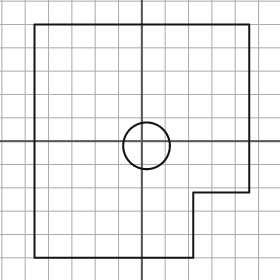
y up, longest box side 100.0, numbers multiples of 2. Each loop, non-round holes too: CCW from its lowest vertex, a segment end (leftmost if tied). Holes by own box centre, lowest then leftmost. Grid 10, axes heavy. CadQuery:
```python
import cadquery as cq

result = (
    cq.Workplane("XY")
    .moveTo(-46.0, -50.0)
    .lineTo(22.0, -50.0)
    .lineTo(22.0, -22.0)
    .lineTo(46.0, -22.0)
    .lineTo(46.0, 50.0)
    .lineTo(-46.0, 50.0)
    .close()
    .moveTo(2.0, -2.0)
    .circle(10.0)
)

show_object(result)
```